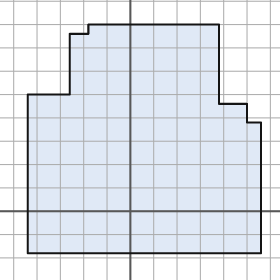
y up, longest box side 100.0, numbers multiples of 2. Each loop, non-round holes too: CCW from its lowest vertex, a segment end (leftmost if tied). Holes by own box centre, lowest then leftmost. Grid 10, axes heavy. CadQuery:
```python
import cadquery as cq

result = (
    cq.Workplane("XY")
    .moveTo(-44.0, -18.0)
    .lineTo(56.0, -18.0)
    .lineTo(56.0, 38.0)
    .lineTo(50.0, 38.0)
    .lineTo(50.0, 46.0)
    .lineTo(38.0, 46.0)
    .lineTo(38.0, 80.0)
    .lineTo(-18.0, 80.0)
    .lineTo(-18.0, 76.0)
    .lineTo(-26.0, 76.0)
    .lineTo(-26.0, 50.0)
    .lineTo(-44.0, 50.0)
    .close()
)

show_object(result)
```